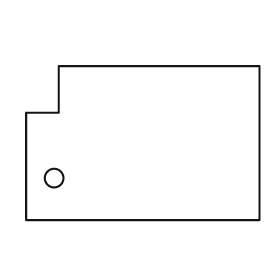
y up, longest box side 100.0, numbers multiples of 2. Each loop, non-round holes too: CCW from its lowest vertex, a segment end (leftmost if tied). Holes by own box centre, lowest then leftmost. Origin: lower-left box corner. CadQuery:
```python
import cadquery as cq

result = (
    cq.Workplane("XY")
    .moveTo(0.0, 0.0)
    .lineTo(100.0, 0.0)
    .lineTo(100.0, 66.0)
    .lineTo(14.0, 66.0)
    .lineTo(14.0, 46.0)
    .lineTo(0.0, 46.0)
    .close()
    .moveTo(12.0, 18.0)
    .circle(4.0)
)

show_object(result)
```